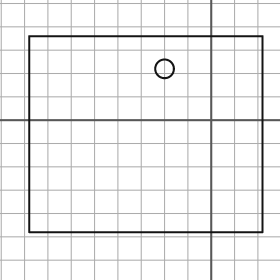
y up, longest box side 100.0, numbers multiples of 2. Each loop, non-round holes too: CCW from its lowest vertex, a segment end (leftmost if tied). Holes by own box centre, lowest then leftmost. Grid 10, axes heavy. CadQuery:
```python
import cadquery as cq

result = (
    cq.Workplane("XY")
    .moveTo(-78.0, -48.0)
    .lineTo(22.0, -48.0)
    .lineTo(22.0, 36.0)
    .lineTo(-78.0, 36.0)
    .close()
    .moveTo(-20.0, 22.0)
    .circle(4.0)
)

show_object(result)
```